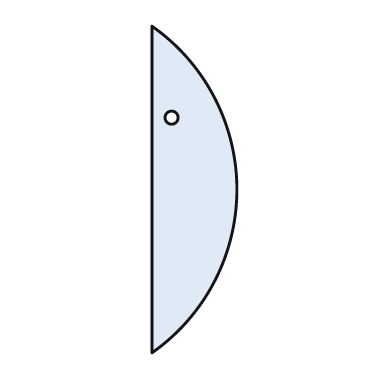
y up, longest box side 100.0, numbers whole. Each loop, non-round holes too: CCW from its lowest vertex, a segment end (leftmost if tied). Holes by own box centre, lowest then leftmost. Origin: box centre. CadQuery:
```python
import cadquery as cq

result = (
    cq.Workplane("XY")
    .moveTo(-13.0, -50.0)
    .threePointArc((13.0, 0.0), (-13.0, 50.0))
    .close()
    .moveTo(-7.0, 22.0)
    .circle(2.0)
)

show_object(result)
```